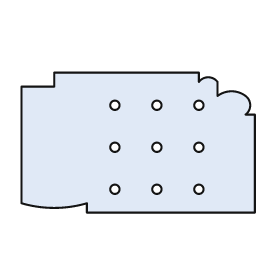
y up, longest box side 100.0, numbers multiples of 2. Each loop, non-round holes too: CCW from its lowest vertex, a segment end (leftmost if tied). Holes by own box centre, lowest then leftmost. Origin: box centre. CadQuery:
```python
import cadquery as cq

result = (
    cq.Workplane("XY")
    .moveTo(-22.0, -30.0)
    .lineTo(50.0, -30.0)
    .lineTo(50.0, 12.0)
    .lineTo(46.0, 12.0)
    .threePointArc((48.0, 16.0), (46.0, 20.0))
    .threePointArc((40.0, 22.0), (34.0, 20.0))
    .lineTo(34.0, 26.0)
    .threePointArc((30.0, 28.0), (26.0, 26.0))
    .lineTo(26.0, 30.0)
    .lineTo(-36.0, 30.0)
    .lineTo(-36.0, 24.0)
    .lineTo(-50.0, 24.0)
    .lineTo(-50.0, -26.0)
    .threePointArc((-36.0, -28.0), (-22.0, -26.0))
    .close()
    .moveTo(-10.0, -20.0)
    .circle(2.0)
    .moveTo(8.0, -20.0)
    .circle(2.0)
    .moveTo(26.0, -20.0)
    .circle(2.0)
    .moveTo(-10.0, -2.0)
    .circle(2.0)
    .moveTo(8.0, -2.0)
    .circle(2.0)
    .moveTo(26.0, -2.0)
    .circle(2.0)
    .moveTo(-10.0, 16.0)
    .circle(2.0)
    .moveTo(8.0, 16.0)
    .circle(2.0)
    .moveTo(26.0, 16.0)
    .circle(2.0)
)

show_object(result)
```